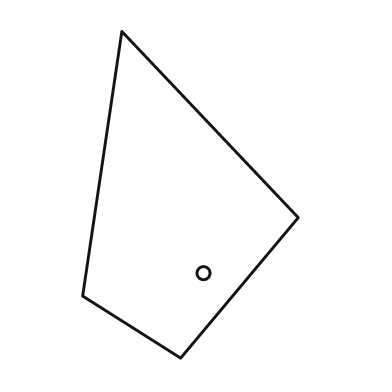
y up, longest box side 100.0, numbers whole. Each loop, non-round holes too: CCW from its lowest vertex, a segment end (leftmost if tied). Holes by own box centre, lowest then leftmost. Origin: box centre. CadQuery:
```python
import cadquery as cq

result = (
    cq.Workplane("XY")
    .moveTo(-3.0, -50.0)
    .lineTo(33.0, -7.0)
    .lineTo(-21.0, 50.0)
    .lineTo(-33.0, -31.0)
    .close()
    .moveTo(4.0, -24.0)
    .circle(2.0)
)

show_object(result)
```